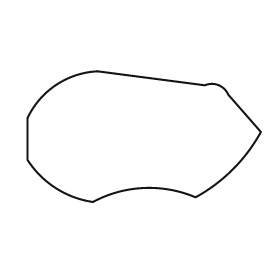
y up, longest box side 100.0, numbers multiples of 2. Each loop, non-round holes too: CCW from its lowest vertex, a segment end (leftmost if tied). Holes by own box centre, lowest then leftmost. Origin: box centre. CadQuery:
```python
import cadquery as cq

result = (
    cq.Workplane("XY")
    .moveTo(-22.0, -28.0)
    .threePointArc((0.0, -22.0), (22.0, -26.0))
    .threePointArc((38.0, -14.0), (50.0, 2.0))
    .lineTo(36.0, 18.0)
    .threePointArc((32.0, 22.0), (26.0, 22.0))
    .lineTo(-20.0, 28.0)
    .threePointArc((-38.0, 22.0), (-50.0, 8.0))
    .lineTo(-50.0, -10.0)
    .threePointArc((-38.0, -22.0), (-22.0, -28.0))
    .close()
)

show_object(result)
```